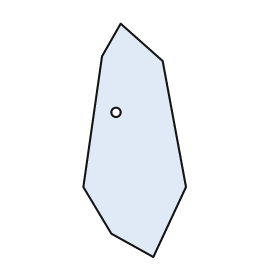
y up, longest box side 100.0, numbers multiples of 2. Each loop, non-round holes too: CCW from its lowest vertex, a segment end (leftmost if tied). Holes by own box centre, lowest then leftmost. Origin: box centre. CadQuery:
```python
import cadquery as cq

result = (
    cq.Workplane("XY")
    .moveTo(8.0, -50.0)
    .lineTo(22.0, -20.0)
    .lineTo(12.0, 34.0)
    .lineTo(-6.0, 50.0)
    .lineTo(-14.0, 36.0)
    .lineTo(-22.0, -20.0)
    .lineTo(-10.0, -40.0)
    .close()
    .moveTo(-8.0, 12.0)
    .circle(2.0)
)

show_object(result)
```